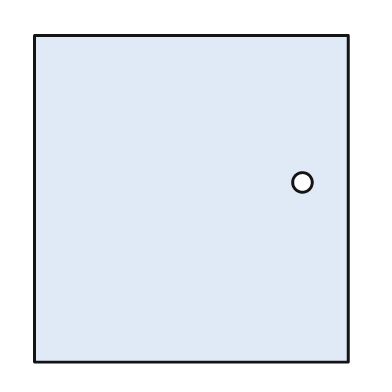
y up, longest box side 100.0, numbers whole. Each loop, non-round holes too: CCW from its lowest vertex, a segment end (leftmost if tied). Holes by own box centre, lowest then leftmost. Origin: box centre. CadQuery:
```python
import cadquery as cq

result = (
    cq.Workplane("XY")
    .moveTo(-48.0, -50.0)
    .lineTo(48.0, -50.0)
    .lineTo(48.0, 50.0)
    .lineTo(-48.0, 50.0)
    .close()
    .moveTo(34.0, 5.0)
    .circle(3.0)
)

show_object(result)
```